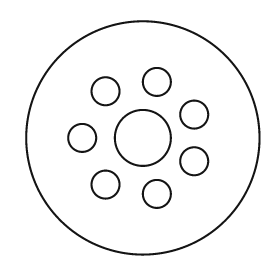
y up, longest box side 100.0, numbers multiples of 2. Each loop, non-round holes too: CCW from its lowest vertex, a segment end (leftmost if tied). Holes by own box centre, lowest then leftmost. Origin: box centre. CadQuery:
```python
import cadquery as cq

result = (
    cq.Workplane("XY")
    .moveTo(0.0, 0.0)
    .circle(50.0)
    .moveTo(6.0, -24.0)
    .circle(6.0)
    .moveTo(-16.0, -20.0)
    .circle(6.0)
    .moveTo(22.0, -10.0)
    .circle(6.0)
    .moveTo(-26.0, 0.0)
    .circle(6.0)
    .moveTo(0.0, 0.0)
    .circle(12.0)
    .moveTo(22.0, 10.0)
    .circle(6.0)
    .moveTo(-16.0, 20.0)
    .circle(6.0)
    .moveTo(6.0, 24.0)
    .circle(6.0)
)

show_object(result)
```